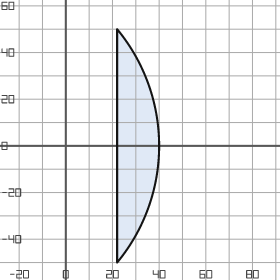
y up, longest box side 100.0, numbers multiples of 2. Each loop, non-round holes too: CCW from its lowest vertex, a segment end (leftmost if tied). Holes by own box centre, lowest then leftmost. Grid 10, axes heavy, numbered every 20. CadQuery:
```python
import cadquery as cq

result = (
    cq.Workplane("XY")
    .moveTo(22.0, -50.0)
    .threePointArc((40.0, 0.0), (22.0, 50.0))
    .close()
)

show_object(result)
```